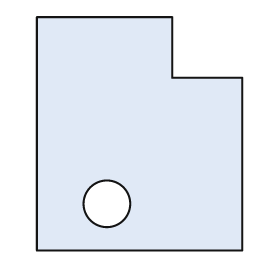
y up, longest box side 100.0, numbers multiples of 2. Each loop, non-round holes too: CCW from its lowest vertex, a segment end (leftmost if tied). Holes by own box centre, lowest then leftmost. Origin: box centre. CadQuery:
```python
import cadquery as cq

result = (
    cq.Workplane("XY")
    .moveTo(-44.0, -50.0)
    .lineTo(44.0, -50.0)
    .lineTo(44.0, 24.0)
    .lineTo(14.0, 24.0)
    .lineTo(14.0, 50.0)
    .lineTo(-44.0, 50.0)
    .close()
    .moveTo(-14.0, -30.0)
    .circle(10.0)
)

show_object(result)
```